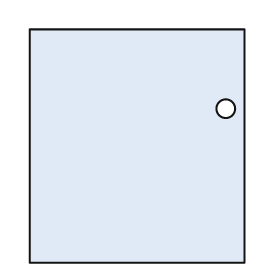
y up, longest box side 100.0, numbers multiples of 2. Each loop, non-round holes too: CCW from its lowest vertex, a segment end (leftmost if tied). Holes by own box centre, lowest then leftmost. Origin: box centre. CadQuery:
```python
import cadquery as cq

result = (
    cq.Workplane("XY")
    .moveTo(-46.0, -50.0)
    .lineTo(46.0, -50.0)
    .lineTo(46.0, 50.0)
    .lineTo(-46.0, 50.0)
    .close()
    .moveTo(38.0, 16.0)
    .circle(4.0)
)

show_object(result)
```